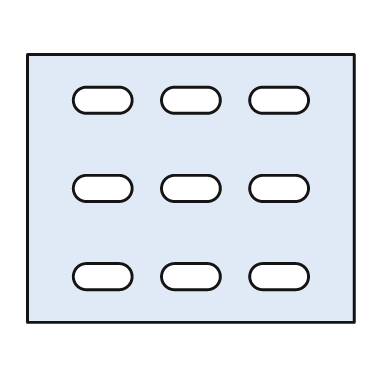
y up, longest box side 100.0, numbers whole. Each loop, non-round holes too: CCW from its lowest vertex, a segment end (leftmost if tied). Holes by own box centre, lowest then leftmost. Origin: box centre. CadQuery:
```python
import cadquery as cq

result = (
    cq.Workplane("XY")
    .moveTo(-50.0, -41.0)
    .lineTo(50.0, -41.0)
    .lineTo(50.0, 41.0)
    .lineTo(-50.0, 41.0)
    .close()
    .moveTo(-32.0, -31.0)
    .lineTo(-22.0, -31.0)
    .threePointArc((-18.0, -27.0), (-22.0, -23.0))
    .lineTo(-32.0, -23.0)
    .threePointArc((-36.0, -27.0), (-32.0, -31.0))
    .close()
    .moveTo(-5.0, -31.0)
    .lineTo(5.0, -31.0)
    .threePointArc((9.0, -27.0), (5.0, -23.0))
    .lineTo(-5.0, -23.0)
    .threePointArc((-9.0, -27.0), (-5.0, -31.0))
    .close()
    .moveTo(22.0, -31.0)
    .lineTo(32.0, -31.0)
    .threePointArc((36.0, -27.0), (32.0, -23.0))
    .lineTo(22.0, -23.0)
    .threePointArc((18.0, -27.0), (22.0, -31.0))
    .close()
    .moveTo(-32.0, -4.0)
    .lineTo(-22.0, -4.0)
    .threePointArc((-18.0, 0.0), (-22.0, 4.0))
    .lineTo(-32.0, 4.0)
    .threePointArc((-36.0, 0.0), (-32.0, -4.0))
    .close()
    .moveTo(-5.0, -4.0)
    .lineTo(5.0, -4.0)
    .threePointArc((9.0, 0.0), (5.0, 4.0))
    .lineTo(-5.0, 4.0)
    .threePointArc((-9.0, 0.0), (-5.0, -4.0))
    .close()
    .moveTo(22.0, -4.0)
    .lineTo(32.0, -4.0)
    .threePointArc((36.0, 0.0), (32.0, 4.0))
    .lineTo(22.0, 4.0)
    .threePointArc((18.0, 0.0), (22.0, -4.0))
    .close()
    .moveTo(-32.0, 23.0)
    .lineTo(-22.0, 23.0)
    .threePointArc((-18.0, 27.0), (-22.0, 31.0))
    .lineTo(-32.0, 31.0)
    .threePointArc((-36.0, 27.0), (-32.0, 23.0))
    .close()
    .moveTo(-5.0, 23.0)
    .lineTo(5.0, 23.0)
    .threePointArc((9.0, 27.0), (5.0, 31.0))
    .lineTo(-5.0, 31.0)
    .threePointArc((-9.0, 27.0), (-5.0, 23.0))
    .close()
    .moveTo(22.0, 23.0)
    .lineTo(32.0, 23.0)
    .threePointArc((36.0, 27.0), (32.0, 31.0))
    .lineTo(22.0, 31.0)
    .threePointArc((18.0, 27.0), (22.0, 23.0))
    .close()
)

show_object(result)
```